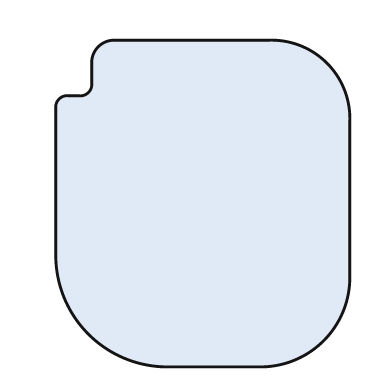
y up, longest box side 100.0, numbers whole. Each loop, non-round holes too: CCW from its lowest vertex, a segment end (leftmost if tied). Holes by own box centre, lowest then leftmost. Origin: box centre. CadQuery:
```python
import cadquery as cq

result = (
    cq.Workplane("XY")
    .moveTo(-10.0, -50.0)
    .lineTo(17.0, -50.0)
    .threePointArc((37.0, -42.0), (45.0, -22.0))
    .lineTo(45.0, 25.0)
    .threePointArc((38.0, 43.0), (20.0, 50.0))
    .lineTo(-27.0, 50.0)
    .threePointArc((-32.0, 48.0), (-34.0, 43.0))
    .lineTo(-34.0, 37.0)
    .threePointArc((-35.0, 34.0), (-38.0, 33.0))
    .lineTo(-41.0, 33.0)
    .threePointArc((-44.0, 32.0), (-45.0, 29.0))
    .lineTo(-45.0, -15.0)
    .threePointArc((-35.0, -40.0), (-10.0, -50.0))
    .close()
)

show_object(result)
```